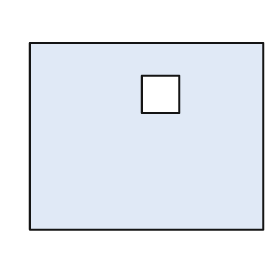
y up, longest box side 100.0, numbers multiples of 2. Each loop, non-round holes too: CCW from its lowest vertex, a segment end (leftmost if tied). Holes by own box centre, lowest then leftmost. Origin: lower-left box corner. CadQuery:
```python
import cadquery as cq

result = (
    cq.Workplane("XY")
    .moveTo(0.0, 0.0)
    .lineTo(100.0, 0.0)
    .lineTo(100.0, 80.0)
    .lineTo(0.0, 80.0)
    .close()
    .moveTo(48.0, 50.0)
    .lineTo(64.0, 50.0)
    .lineTo(64.0, 66.0)
    .lineTo(48.0, 66.0)
    .close()
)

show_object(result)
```